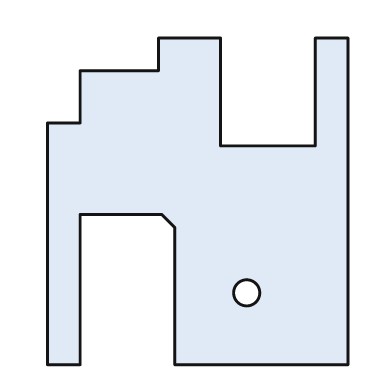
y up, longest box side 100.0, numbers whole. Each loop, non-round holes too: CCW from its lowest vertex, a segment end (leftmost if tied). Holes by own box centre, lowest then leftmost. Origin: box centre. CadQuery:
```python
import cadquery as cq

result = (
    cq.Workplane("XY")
    .moveTo(-46.0, -50.0)
    .lineTo(-36.0, -50.0)
    .lineTo(-36.0, -4.0)
    .lineTo(-11.0, -4.0)
    .lineTo(-7.0, -8.0)
    .lineTo(-7.0, -50.0)
    .lineTo(46.0, -50.0)
    .lineTo(46.0, 50.0)
    .lineTo(36.0, 50.0)
    .lineTo(36.0, 17.0)
    .lineTo(7.0, 17.0)
    .lineTo(7.0, 50.0)
    .lineTo(-12.0, 50.0)
    .lineTo(-12.0, 40.0)
    .lineTo(-36.0, 40.0)
    .lineTo(-36.0, 24.0)
    .lineTo(-46.0, 24.0)
    .close()
    .moveTo(15.0, -28.0)
    .circle(4.0)
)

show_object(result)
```